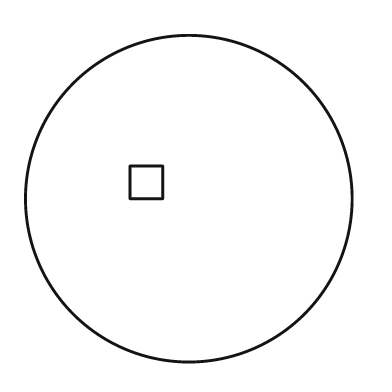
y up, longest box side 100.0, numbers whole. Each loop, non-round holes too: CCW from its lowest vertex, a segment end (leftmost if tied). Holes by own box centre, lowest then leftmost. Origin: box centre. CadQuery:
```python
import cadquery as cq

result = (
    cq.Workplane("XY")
    .moveTo(0.0, 0.0)
    .circle(50.0)
    .moveTo(-18.0, 0.0)
    .lineTo(-8.0, 0.0)
    .lineTo(-8.0, 10.0)
    .lineTo(-18.0, 10.0)
    .close()
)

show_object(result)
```